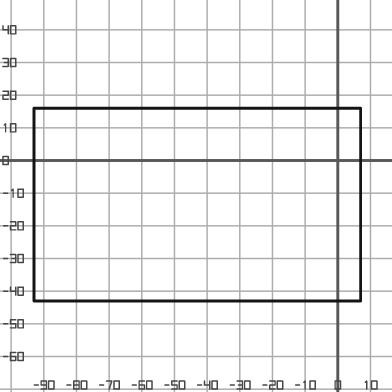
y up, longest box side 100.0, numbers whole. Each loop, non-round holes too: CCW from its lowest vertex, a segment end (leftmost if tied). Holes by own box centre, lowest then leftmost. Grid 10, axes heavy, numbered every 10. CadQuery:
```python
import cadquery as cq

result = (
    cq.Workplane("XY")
    .moveTo(-93.0, -43.0)
    .lineTo(7.0, -43.0)
    .lineTo(7.0, 16.0)
    .lineTo(-93.0, 16.0)
    .close()
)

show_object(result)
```